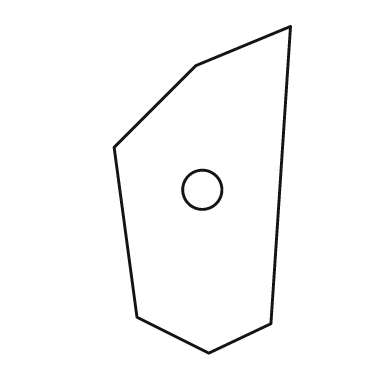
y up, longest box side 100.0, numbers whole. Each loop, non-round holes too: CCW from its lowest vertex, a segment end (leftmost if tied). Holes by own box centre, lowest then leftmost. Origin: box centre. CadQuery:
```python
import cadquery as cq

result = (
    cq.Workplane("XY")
    .moveTo(2.0, -50.0)
    .lineTo(21.0, -41.0)
    .lineTo(27.0, 50.0)
    .lineTo(-2.0, 38.0)
    .lineTo(-27.0, 13.0)
    .lineTo(-20.0, -39.0)
    .close()
    .moveTo(0.0, 0.0)
    .circle(6.0)
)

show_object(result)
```